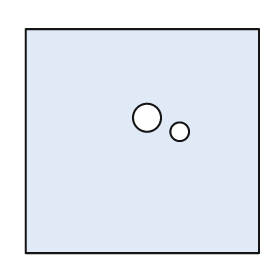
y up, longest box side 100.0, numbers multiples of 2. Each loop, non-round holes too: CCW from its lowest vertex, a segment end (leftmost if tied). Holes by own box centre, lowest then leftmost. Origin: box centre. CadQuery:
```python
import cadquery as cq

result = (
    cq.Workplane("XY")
    .moveTo(-50.0, -48.0)
    .lineTo(50.0, -48.0)
    .lineTo(50.0, 48.0)
    .lineTo(-50.0, 48.0)
    .close()
    .moveTo(16.0, 4.0)
    .circle(4.0)
    .moveTo(2.0, 10.0)
    .circle(6.0)
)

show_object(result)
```